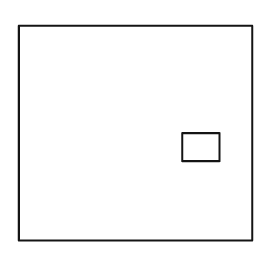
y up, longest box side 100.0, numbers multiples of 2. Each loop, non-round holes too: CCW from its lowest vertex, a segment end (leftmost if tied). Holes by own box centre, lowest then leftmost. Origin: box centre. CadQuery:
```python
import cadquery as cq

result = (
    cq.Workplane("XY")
    .moveTo(-50.0, -46.0)
    .lineTo(50.0, -46.0)
    .lineTo(50.0, 46.0)
    .lineTo(-50.0, 46.0)
    .close()
    .moveTo(20.0, -12.0)
    .lineTo(36.0, -12.0)
    .lineTo(36.0, 0.0)
    .lineTo(20.0, 0.0)
    .close()
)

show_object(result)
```